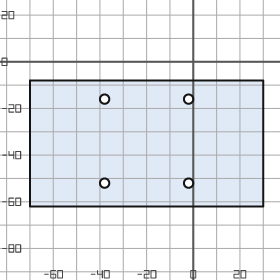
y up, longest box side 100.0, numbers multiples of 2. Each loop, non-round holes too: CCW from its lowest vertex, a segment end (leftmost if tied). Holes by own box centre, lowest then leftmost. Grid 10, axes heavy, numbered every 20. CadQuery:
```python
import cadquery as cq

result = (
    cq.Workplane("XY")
    .moveTo(-70.0, -62.0)
    .lineTo(30.0, -62.0)
    .lineTo(30.0, -8.0)
    .lineTo(-70.0, -8.0)
    .close()
    .moveTo(-38.0, -52.0)
    .circle(2.0)
    .moveTo(-2.0, -52.0)
    .circle(2.0)
    .moveTo(-38.0, -16.0)
    .circle(2.0)
    .moveTo(-2.0, -16.0)
    .circle(2.0)
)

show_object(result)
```